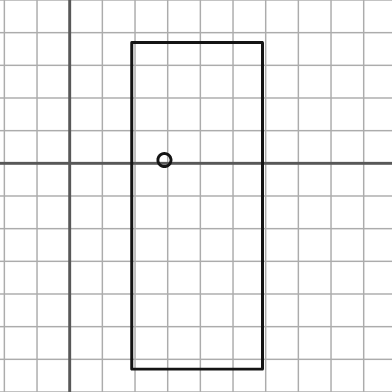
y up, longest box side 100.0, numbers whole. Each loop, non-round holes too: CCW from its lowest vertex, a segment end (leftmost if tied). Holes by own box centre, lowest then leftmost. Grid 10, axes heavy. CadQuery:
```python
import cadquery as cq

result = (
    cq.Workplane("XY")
    .moveTo(19.0, -63.0)
    .lineTo(59.0, -63.0)
    .lineTo(59.0, 37.0)
    .lineTo(19.0, 37.0)
    .close()
    .moveTo(29.0, 1.0)
    .circle(2.0)
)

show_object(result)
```